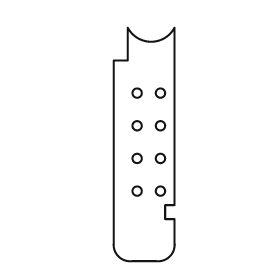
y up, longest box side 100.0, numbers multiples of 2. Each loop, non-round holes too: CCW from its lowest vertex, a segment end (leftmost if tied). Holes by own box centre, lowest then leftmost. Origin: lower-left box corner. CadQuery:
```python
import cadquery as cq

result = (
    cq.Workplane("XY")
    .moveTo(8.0, 0.0)
    .lineTo(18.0, 0.0)
    .threePointArc((24.0, 2.0), (26.0, 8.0))
    .lineTo(26.0, 18.0)
    .lineTo(22.0, 18.0)
    .lineTo(22.0, 24.0)
    .lineTo(26.0, 24.0)
    .lineTo(26.0, 100.0)
    .threePointArc((16.0, 94.0), (6.0, 100.0))
    .lineTo(6.0, 86.0)
    .lineTo(0.0, 86.0)
    .lineTo(0.0, 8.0)
    .threePointArc((2.0, 2.0), (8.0, 0.0))
    .close()
    .moveTo(10.0, 30.0)
    .circle(2.0)
    .moveTo(20.0, 30.0)
    .circle(2.0)
    .moveTo(10.0, 44.0)
    .circle(2.0)
    .moveTo(20.0, 44.0)
    .circle(2.0)
    .moveTo(10.0, 58.0)
    .circle(2.0)
    .moveTo(20.0, 58.0)
    .circle(2.0)
    .moveTo(10.0, 72.0)
    .circle(2.0)
    .moveTo(20.0, 72.0)
    .circle(2.0)
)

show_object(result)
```